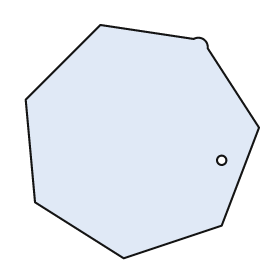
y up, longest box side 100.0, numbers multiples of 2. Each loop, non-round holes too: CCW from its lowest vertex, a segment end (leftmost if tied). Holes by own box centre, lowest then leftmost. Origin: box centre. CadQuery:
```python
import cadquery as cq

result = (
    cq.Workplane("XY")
    .moveTo(-8.0, -50.0)
    .lineTo(34.0, -36.0)
    .lineTo(50.0, 6.0)
    .lineTo(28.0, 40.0)
    .threePointArc((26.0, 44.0), (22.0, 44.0))
    .lineTo(-18.0, 50.0)
    .lineTo(-50.0, 18.0)
    .lineTo(-46.0, -26.0)
    .close()
    .moveTo(34.0, -8.0)
    .circle(2.0)
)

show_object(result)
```